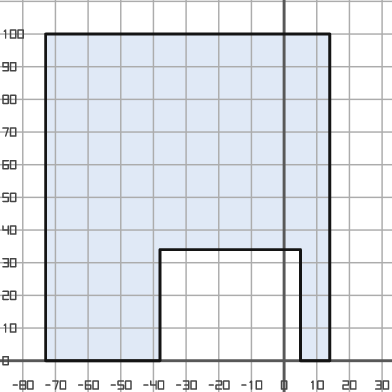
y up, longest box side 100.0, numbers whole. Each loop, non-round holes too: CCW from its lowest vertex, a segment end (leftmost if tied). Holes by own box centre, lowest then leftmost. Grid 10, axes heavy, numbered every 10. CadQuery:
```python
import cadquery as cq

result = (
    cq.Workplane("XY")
    .moveTo(-73.0, 0.0)
    .lineTo(-38.0, 0.0)
    .lineTo(-38.0, 34.0)
    .lineTo(5.0, 34.0)
    .lineTo(5.0, 0.0)
    .lineTo(14.0, 0.0)
    .lineTo(14.0, 100.0)
    .lineTo(-73.0, 100.0)
    .close()
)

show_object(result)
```